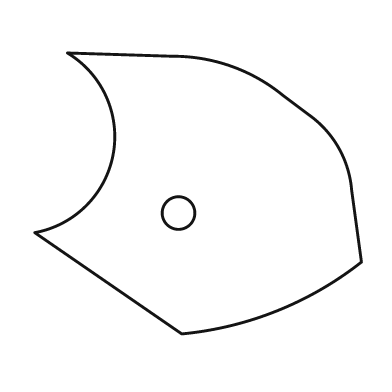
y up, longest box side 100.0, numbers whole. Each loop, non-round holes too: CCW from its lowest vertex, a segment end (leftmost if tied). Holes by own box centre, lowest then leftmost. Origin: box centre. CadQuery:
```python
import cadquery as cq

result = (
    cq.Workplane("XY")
    .moveTo(-5.0, -43.0)
    .threePointArc((24.0, -36.0), (50.0, -21.0))
    .lineTo(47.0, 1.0)
    .threePointArc((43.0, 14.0), (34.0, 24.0))
    .lineTo(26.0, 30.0)
    .threePointArc((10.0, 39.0), (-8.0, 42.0))
    .lineTo(-40.0, 43.0)
    .threePointArc((-26.0, 12.0), (-50.0, -12.0))
    .close()
    .moveTo(-6.0, -6.0)
    .circle(5.0)
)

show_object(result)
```